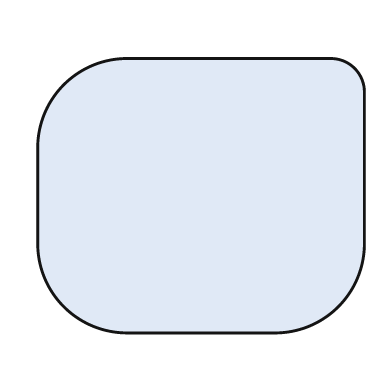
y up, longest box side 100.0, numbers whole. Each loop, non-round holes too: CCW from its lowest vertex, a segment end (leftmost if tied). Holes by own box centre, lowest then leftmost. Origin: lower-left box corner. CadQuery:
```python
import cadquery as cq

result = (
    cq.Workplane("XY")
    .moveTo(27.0, 0.0)
    .lineTo(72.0, 0.0)
    .threePointArc((92.0, 8.0), (100.0, 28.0))
    .lineTo(100.0, 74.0)
    .threePointArc((97.0, 81.0), (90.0, 84.0))
    .lineTo(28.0, 84.0)
    .threePointArc((8.0, 76.0), (0.0, 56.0))
    .lineTo(0.0, 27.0)
    .threePointArc((8.0, 8.0), (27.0, 0.0))
    .close()
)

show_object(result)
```